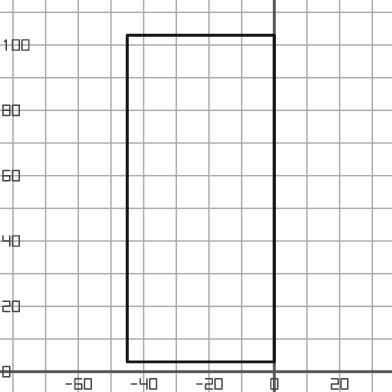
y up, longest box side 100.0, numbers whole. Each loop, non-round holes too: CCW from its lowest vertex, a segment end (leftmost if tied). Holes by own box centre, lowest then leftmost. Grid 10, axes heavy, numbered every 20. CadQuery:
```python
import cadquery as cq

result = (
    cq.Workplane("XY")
    .moveTo(-45.0, 3.0)
    .lineTo(0.0, 3.0)
    .lineTo(0.0, 103.0)
    .lineTo(-45.0, 103.0)
    .close()
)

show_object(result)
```